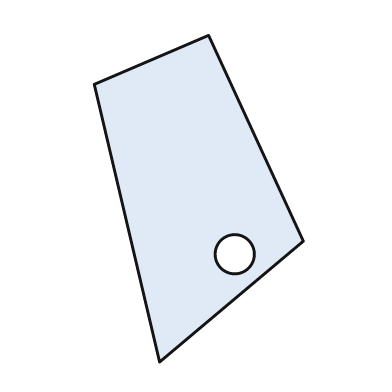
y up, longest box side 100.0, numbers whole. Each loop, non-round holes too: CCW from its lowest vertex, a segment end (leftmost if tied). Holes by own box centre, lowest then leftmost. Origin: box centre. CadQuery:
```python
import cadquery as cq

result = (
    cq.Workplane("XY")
    .moveTo(-12.0, -50.0)
    .lineTo(32.0, -13.0)
    .lineTo(3.0, 50.0)
    .lineTo(-32.0, 35.0)
    .close()
    .moveTo(11.0, -17.0)
    .circle(6.0)
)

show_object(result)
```